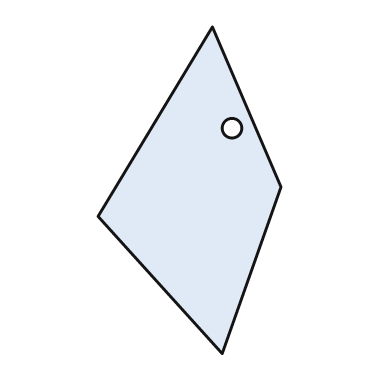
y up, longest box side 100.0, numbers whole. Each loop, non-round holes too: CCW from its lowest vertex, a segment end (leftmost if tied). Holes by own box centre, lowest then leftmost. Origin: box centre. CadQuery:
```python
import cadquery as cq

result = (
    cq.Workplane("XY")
    .moveTo(10.0, -50.0)
    .lineTo(28.0, 1.0)
    .lineTo(7.0, 50.0)
    .lineTo(-28.0, -8.0)
    .close()
    .moveTo(13.0, 19.0)
    .circle(3.0)
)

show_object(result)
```